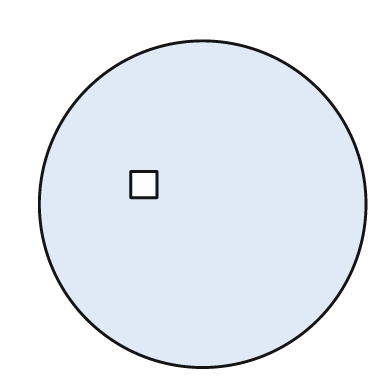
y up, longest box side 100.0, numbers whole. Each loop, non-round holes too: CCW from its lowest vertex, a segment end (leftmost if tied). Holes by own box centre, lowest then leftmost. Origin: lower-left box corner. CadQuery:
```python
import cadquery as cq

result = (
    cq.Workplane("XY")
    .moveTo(50.0, 50.0)
    .circle(50.0)
    .moveTo(28.0, 52.0)
    .lineTo(36.0, 52.0)
    .lineTo(36.0, 60.0)
    .lineTo(28.0, 60.0)
    .close()
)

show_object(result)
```